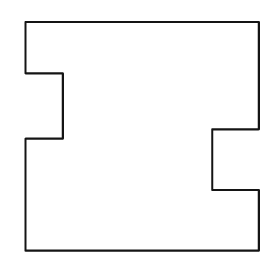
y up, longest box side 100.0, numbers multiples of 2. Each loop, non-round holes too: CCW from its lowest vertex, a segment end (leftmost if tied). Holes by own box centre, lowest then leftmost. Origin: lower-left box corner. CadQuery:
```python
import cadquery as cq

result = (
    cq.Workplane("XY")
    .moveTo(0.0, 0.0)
    .lineTo(100.0, 0.0)
    .lineTo(100.0, 26.0)
    .lineTo(80.0, 26.0)
    .lineTo(80.0, 52.0)
    .lineTo(100.0, 52.0)
    .lineTo(100.0, 98.0)
    .lineTo(0.0, 98.0)
    .lineTo(0.0, 76.0)
    .lineTo(16.0, 76.0)
    .lineTo(16.0, 48.0)
    .lineTo(0.0, 48.0)
    .close()
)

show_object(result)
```